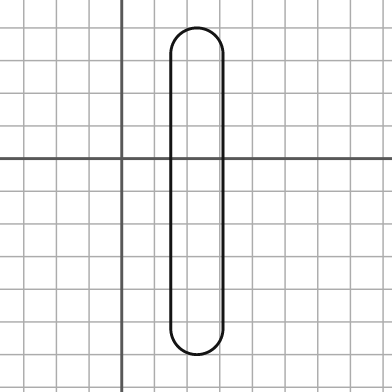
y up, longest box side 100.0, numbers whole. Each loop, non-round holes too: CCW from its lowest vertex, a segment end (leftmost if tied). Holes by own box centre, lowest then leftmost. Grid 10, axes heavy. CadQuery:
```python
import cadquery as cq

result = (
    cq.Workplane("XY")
    .moveTo(15.0, -52.0)
    .threePointArc((23.0, -60.0), (31.0, -52.0))
    .lineTo(31.0, 32.0)
    .threePointArc((23.0, 40.0), (15.0, 32.0))
    .close()
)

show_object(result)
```